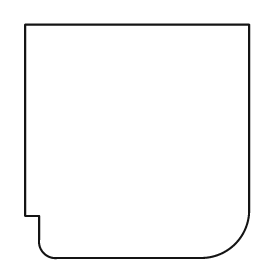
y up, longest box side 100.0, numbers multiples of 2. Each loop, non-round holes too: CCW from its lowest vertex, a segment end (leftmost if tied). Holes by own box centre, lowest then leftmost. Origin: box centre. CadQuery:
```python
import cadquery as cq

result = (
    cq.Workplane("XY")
    .moveTo(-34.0, -50.0)
    .lineTo(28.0, -50.0)
    .threePointArc((42.0, -44.0), (48.0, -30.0))
    .lineTo(48.0, 50.0)
    .lineTo(-48.0, 50.0)
    .lineTo(-48.0, -32.0)
    .lineTo(-42.0, -32.0)
    .lineTo(-42.0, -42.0)
    .threePointArc((-40.0, -48.0), (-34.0, -50.0))
    .close()
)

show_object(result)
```